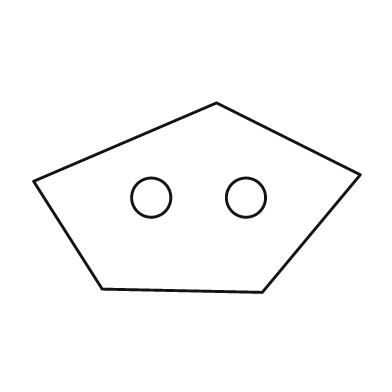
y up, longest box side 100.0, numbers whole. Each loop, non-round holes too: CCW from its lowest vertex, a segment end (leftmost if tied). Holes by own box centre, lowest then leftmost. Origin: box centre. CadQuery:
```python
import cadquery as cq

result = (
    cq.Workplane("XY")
    .moveTo(20.0, -29.0)
    .lineTo(50.0, 7.0)
    .lineTo(6.0, 29.0)
    .lineTo(-50.0, 5.0)
    .lineTo(-29.0, -28.0)
    .close()
    .moveTo(-14.0, 0.0)
    .circle(6.0)
    .moveTo(15.0, 0.0)
    .circle(6.0)
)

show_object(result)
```